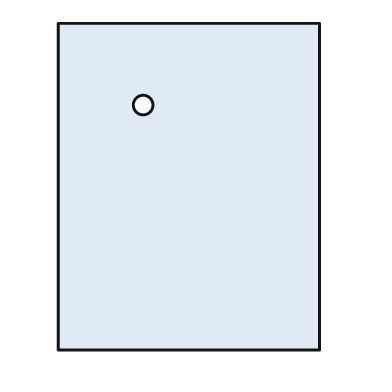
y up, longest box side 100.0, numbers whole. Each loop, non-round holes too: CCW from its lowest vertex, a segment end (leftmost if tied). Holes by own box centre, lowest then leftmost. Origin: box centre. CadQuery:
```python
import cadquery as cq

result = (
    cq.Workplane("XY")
    .moveTo(-40.0, -50.0)
    .lineTo(40.0, -50.0)
    .lineTo(40.0, 50.0)
    .lineTo(-40.0, 50.0)
    .close()
    .moveTo(-14.0, 25.0)
    .circle(3.0)
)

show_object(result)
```